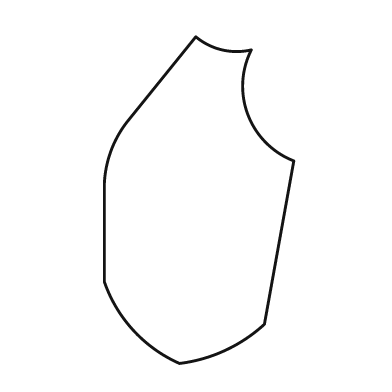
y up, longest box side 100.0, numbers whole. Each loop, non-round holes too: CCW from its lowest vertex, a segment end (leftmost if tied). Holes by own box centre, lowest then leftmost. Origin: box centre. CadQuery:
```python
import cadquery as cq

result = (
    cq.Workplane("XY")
    .moveTo(-6.0, -50.0)
    .threePointArc((8.0, -46.0), (20.0, -38.0))
    .lineTo(29.0, 12.0)
    .threePointArc((15.0, 26.0), (16.0, 46.0))
    .threePointArc((7.0, 46.0), (-1.0, 50.0))
    .lineTo(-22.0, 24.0)
    .threePointArc((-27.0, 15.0), (-29.0, 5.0))
    .lineTo(-29.0, -25.0)
    .threePointArc((-20.0, -40.0), (-6.0, -50.0))
    .close()
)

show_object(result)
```